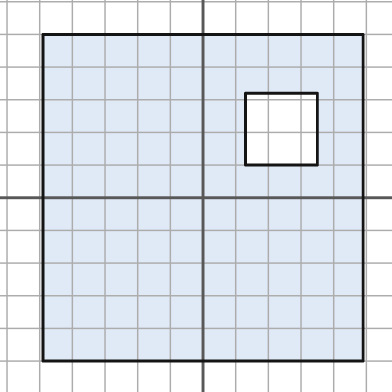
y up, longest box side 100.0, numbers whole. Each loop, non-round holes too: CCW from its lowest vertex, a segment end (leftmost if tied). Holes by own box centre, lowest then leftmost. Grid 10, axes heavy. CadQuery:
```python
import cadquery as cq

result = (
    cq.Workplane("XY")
    .moveTo(-49.0, -50.0)
    .lineTo(49.0, -50.0)
    .lineTo(49.0, 50.0)
    .lineTo(-49.0, 50.0)
    .close()
    .moveTo(13.0, 10.0)
    .lineTo(35.0, 10.0)
    .lineTo(35.0, 32.0)
    .lineTo(13.0, 32.0)
    .close()
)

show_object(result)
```